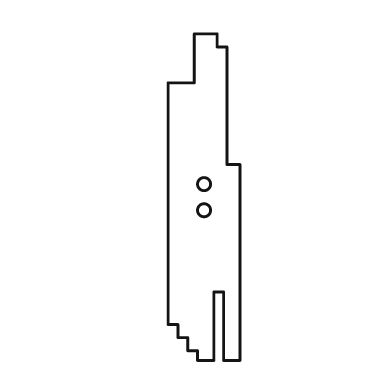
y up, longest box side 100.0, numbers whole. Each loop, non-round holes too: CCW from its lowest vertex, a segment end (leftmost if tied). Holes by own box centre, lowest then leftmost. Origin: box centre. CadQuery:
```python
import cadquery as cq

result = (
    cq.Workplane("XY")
    .moveTo(-2.0, -50.0)
    .lineTo(3.0, -50.0)
    .lineTo(3.0, -29.0)
    .lineTo(6.0, -29.0)
    .lineTo(6.0, -50.0)
    .lineTo(11.0, -50.0)
    .lineTo(11.0, 10.0)
    .lineTo(7.0, 10.0)
    .lineTo(7.0, 46.0)
    .lineTo(4.0, 46.0)
    .lineTo(4.0, 50.0)
    .lineTo(-3.0, 50.0)
    .lineTo(-3.0, 35.0)
    .lineTo(-11.0, 35.0)
    .lineTo(-11.0, -39.0)
    .lineTo(-8.0, -39.0)
    .lineTo(-8.0, -43.0)
    .lineTo(-5.0, -43.0)
    .lineTo(-5.0, -47.0)
    .lineTo(-2.0, -47.0)
    .close()
    .moveTo(0.0, -4.0)
    .circle(2.0)
    .moveTo(0.0, 4.0)
    .circle(2.0)
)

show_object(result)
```